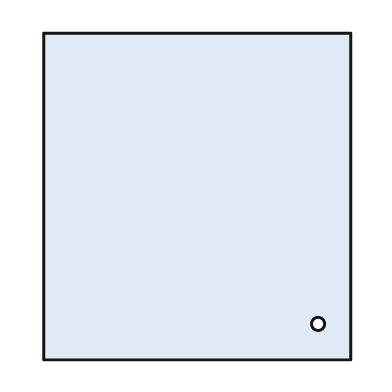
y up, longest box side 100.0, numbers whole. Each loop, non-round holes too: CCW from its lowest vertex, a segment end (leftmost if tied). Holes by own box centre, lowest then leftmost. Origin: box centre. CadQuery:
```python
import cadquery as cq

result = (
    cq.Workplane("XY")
    .moveTo(-47.0, -50.0)
    .lineTo(47.0, -50.0)
    .lineTo(47.0, 50.0)
    .lineTo(-47.0, 50.0)
    .close()
    .moveTo(37.0, -39.0)
    .circle(2.0)
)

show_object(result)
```